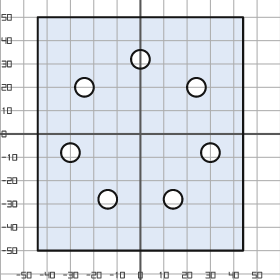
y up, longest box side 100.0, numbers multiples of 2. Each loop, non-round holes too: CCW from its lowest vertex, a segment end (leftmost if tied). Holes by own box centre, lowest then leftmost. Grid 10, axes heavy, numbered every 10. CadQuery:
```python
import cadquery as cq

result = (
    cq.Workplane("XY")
    .moveTo(-44.0, -50.0)
    .lineTo(44.0, -50.0)
    .lineTo(44.0, 50.0)
    .lineTo(-44.0, 50.0)
    .close()
    .moveTo(-14.0, -28.0)
    .circle(4.0)
    .moveTo(14.0, -28.0)
    .circle(4.0)
    .moveTo(-30.0, -8.0)
    .circle(4.0)
    .moveTo(30.0, -8.0)
    .circle(4.0)
    .moveTo(-24.0, 20.0)
    .circle(4.0)
    .moveTo(24.0, 20.0)
    .circle(4.0)
    .moveTo(0.0, 32.0)
    .circle(4.0)
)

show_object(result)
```